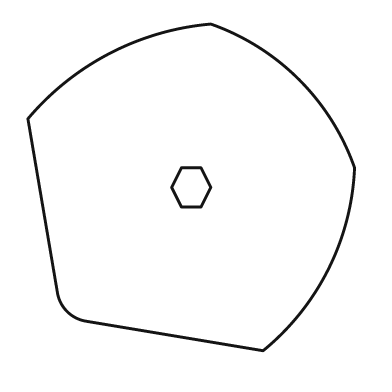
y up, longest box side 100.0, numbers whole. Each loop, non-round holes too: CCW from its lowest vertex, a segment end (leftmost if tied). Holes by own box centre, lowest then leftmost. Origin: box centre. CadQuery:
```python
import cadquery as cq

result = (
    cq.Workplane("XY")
    .moveTo(22.0, -50.0)
    .threePointArc((42.0, -25.0), (50.0, 6.0))
    .threePointArc((33.0, 33.0), (6.0, 50.0))
    .threePointArc((-25.0, 41.0), (-50.0, 21.0))
    .lineTo(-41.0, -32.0)
    .threePointArc((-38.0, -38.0), (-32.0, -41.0))
    .close()
    .moveTo(-3.0, -6.0)
    .lineTo(3.0, -6.0)
    .lineTo(6.0, 0.0)
    .lineTo(3.0, 6.0)
    .lineTo(-3.0, 6.0)
    .lineTo(-6.0, 0.0)
    .close()
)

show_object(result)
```